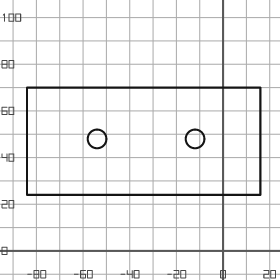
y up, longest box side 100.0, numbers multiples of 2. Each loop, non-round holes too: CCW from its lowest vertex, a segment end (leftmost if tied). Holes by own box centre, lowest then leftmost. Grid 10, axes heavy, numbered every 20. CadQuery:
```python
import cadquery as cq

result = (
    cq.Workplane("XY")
    .moveTo(-84.0, 24.0)
    .lineTo(16.0, 24.0)
    .lineTo(16.0, 70.0)
    .lineTo(-84.0, 70.0)
    .close()
    .moveTo(-54.0, 48.0)
    .circle(4.0)
    .moveTo(-12.0, 48.0)
    .circle(4.0)
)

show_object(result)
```